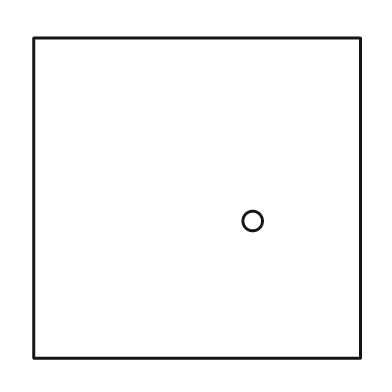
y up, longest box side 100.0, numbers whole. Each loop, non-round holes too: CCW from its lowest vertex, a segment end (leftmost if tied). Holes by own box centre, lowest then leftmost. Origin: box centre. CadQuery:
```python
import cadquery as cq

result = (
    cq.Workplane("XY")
    .moveTo(-50.0, -49.0)
    .lineTo(50.0, -49.0)
    .lineTo(50.0, 49.0)
    .lineTo(-50.0, 49.0)
    .close()
    .moveTo(17.0, -7.0)
    .circle(3.0)
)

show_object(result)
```